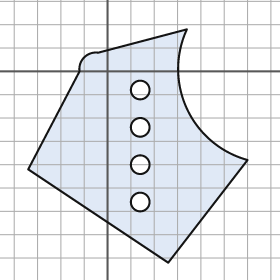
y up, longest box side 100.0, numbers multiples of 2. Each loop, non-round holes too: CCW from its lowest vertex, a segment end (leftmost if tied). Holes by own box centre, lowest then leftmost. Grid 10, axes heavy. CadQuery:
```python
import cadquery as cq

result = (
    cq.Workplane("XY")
    .moveTo(26.0, -82.0)
    .lineTo(60.0, -38.0)
    .threePointArc((34.0, -16.0), (34.0, 18.0))
    .lineTo(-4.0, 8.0)
    .threePointArc((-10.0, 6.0), (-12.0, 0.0))
    .lineTo(-34.0, -42.0)
    .close()
    .moveTo(14.0, -56.0)
    .circle(4.0)
    .moveTo(14.0, -40.0)
    .circle(4.0)
    .moveTo(14.0, -24.0)
    .circle(4.0)
    .moveTo(14.0, -8.0)
    .circle(4.0)
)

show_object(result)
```